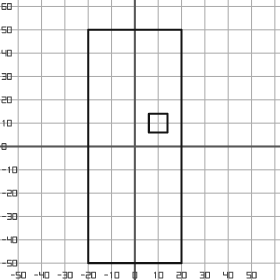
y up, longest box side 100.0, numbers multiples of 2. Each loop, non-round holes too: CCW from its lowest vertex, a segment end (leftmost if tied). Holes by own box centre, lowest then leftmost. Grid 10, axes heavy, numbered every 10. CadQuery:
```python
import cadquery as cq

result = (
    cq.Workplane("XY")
    .moveTo(-20.0, -50.0)
    .lineTo(20.0, -50.0)
    .lineTo(20.0, 50.0)
    .lineTo(-20.0, 50.0)
    .close()
    .moveTo(6.0, 6.0)
    .lineTo(14.0, 6.0)
    .lineTo(14.0, 14.0)
    .lineTo(6.0, 14.0)
    .close()
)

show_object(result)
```